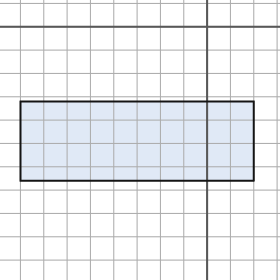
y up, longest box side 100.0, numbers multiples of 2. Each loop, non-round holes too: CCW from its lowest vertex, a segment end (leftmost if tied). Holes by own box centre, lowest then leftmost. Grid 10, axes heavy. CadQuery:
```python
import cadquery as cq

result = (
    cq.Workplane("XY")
    .moveTo(-80.0, -66.0)
    .lineTo(20.0, -66.0)
    .lineTo(20.0, -32.0)
    .lineTo(-80.0, -32.0)
    .close()
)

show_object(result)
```